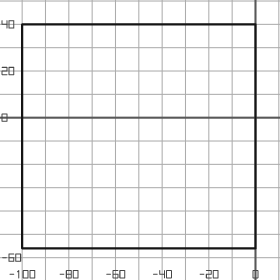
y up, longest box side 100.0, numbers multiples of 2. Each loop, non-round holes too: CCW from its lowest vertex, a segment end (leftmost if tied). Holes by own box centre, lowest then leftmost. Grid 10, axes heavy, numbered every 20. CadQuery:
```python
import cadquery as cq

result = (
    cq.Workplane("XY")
    .moveTo(-100.0, -56.0)
    .lineTo(0.0, -56.0)
    .lineTo(0.0, 40.0)
    .lineTo(-100.0, 40.0)
    .close()
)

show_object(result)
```